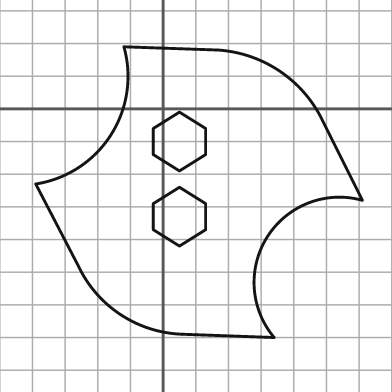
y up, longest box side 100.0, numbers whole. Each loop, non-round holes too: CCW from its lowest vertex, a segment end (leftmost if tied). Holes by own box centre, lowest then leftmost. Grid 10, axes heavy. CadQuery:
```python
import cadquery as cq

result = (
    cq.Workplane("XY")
    .moveTo(34.0, -70.0)
    .threePointArc((32.0, -39.0), (61.0, -28.0))
    .lineTo(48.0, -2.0)
    .threePointArc((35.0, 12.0), (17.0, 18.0))
    .lineTo(-12.0, 19.0)
    .threePointArc((-16.0, -8.0), (-39.0, -23.0))
    .lineTo(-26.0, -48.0)
    .threePointArc((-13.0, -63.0), (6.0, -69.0))
    .close()
    .moveTo(5.0, -42.0)
    .lineTo(13.0, -37.0)
    .lineTo(13.0, -29.0)
    .lineTo(5.0, -24.0)
    .lineTo(-3.0, -29.0)
    .lineTo(-3.0, -37.0)
    .close()
    .moveTo(5.0, -19.0)
    .lineTo(13.0, -14.0)
    .lineTo(13.0, -6.0)
    .lineTo(5.0, -1.0)
    .lineTo(-3.0, -6.0)
    .lineTo(-3.0, -14.0)
    .close()
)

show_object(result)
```